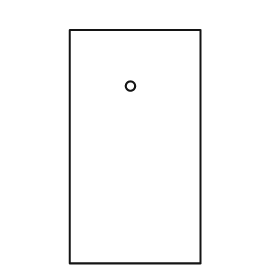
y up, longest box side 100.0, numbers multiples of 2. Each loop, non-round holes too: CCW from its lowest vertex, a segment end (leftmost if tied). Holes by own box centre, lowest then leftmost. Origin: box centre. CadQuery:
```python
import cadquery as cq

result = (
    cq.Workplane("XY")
    .moveTo(-28.0, -50.0)
    .lineTo(28.0, -50.0)
    .lineTo(28.0, 50.0)
    .lineTo(-28.0, 50.0)
    .close()
    .moveTo(-2.0, 26.0)
    .circle(2.0)
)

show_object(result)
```